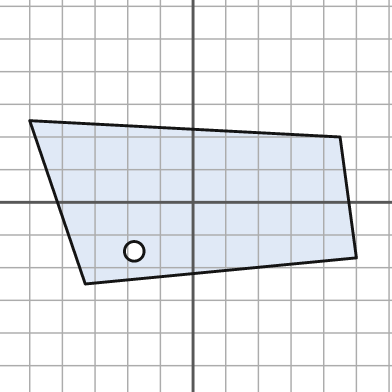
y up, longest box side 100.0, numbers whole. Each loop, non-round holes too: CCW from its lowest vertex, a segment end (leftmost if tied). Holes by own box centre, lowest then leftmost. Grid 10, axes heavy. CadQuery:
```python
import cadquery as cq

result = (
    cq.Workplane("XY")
    .moveTo(-33.0, -25.0)
    .lineTo(50.0, -17.0)
    .lineTo(45.0, 20.0)
    .lineTo(-50.0, 25.0)
    .close()
    .moveTo(-18.0, -15.0)
    .circle(3.0)
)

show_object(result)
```